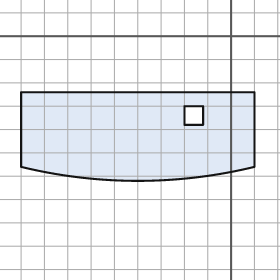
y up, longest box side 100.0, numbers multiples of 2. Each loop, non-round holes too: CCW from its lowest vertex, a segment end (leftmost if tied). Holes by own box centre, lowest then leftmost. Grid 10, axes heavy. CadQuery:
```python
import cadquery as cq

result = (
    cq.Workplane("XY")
    .moveTo(-90.0, -56.0)
    .threePointArc((-40.0, -62.0), (10.0, -56.0))
    .lineTo(10.0, -24.0)
    .lineTo(-90.0, -24.0)
    .close()
    .moveTo(-20.0, -38.0)
    .lineTo(-12.0, -38.0)
    .lineTo(-12.0, -30.0)
    .lineTo(-20.0, -30.0)
    .close()
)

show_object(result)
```